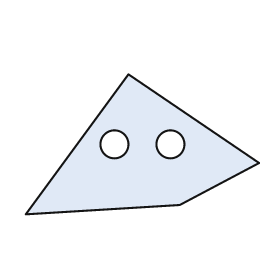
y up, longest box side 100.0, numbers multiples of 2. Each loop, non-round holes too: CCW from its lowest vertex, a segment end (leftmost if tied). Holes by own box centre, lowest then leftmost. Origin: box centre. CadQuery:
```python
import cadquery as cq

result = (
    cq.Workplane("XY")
    .moveTo(-50.0, -30.0)
    .lineTo(16.0, -26.0)
    .lineTo(50.0, -8.0)
    .lineTo(-6.0, 30.0)
    .close()
    .moveTo(-12.0, 0.0)
    .circle(6.0)
    .moveTo(12.0, 0.0)
    .circle(6.0)
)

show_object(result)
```